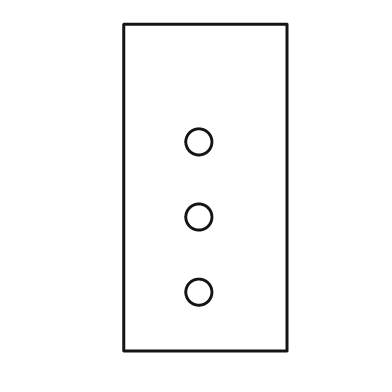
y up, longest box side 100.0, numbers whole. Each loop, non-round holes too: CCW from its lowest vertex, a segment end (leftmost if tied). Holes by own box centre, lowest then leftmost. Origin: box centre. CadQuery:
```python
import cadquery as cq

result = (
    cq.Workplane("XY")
    .moveTo(-25.0, -50.0)
    .lineTo(25.0, -50.0)
    .lineTo(25.0, 50.0)
    .lineTo(-25.0, 50.0)
    .close()
    .moveTo(-2.0, -32.0)
    .circle(4.0)
    .moveTo(-2.0, -9.0)
    .circle(4.0)
    .moveTo(-2.0, 14.0)
    .circle(4.0)
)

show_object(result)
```